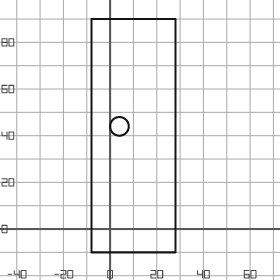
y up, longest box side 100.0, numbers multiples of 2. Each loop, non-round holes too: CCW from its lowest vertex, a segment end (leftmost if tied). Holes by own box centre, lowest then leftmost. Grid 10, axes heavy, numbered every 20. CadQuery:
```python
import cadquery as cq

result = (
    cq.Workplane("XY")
    .moveTo(-8.0, -10.0)
    .lineTo(28.0, -10.0)
    .lineTo(28.0, 90.0)
    .lineTo(-8.0, 90.0)
    .close()
    .moveTo(4.0, 44.0)
    .circle(4.0)
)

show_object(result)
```